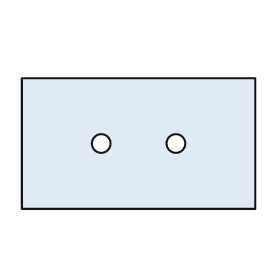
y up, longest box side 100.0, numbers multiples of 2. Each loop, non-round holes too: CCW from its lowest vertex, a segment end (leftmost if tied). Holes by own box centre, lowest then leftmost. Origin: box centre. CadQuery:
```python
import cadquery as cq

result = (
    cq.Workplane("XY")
    .moveTo(-50.0, -28.0)
    .lineTo(50.0, -28.0)
    .lineTo(50.0, 28.0)
    .lineTo(-50.0, 28.0)
    .close()
    .moveTo(-16.0, 0.0)
    .circle(4.0)
    .moveTo(16.0, 0.0)
    .circle(4.0)
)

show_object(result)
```